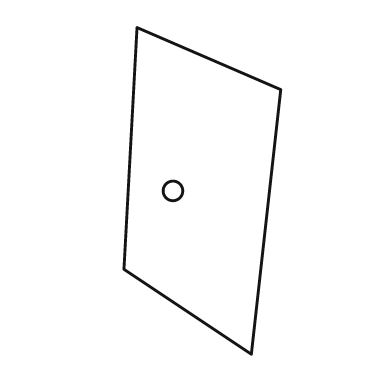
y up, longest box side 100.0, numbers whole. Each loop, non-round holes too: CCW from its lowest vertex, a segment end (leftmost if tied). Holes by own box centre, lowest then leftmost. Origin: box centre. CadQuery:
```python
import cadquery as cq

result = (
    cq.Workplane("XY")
    .moveTo(15.0, -50.0)
    .lineTo(24.0, 31.0)
    .lineTo(-20.0, 50.0)
    .lineTo(-24.0, -24.0)
    .close()
    .moveTo(-9.0, 0.0)
    .circle(3.0)
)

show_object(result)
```